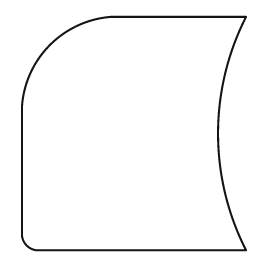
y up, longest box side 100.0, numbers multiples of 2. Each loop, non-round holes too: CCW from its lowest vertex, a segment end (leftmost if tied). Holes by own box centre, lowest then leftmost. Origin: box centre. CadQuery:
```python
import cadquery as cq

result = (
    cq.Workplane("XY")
    .moveTo(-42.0, -50.0)
    .lineTo(48.0, -50.0)
    .threePointArc((36.0, 0.0), (48.0, 50.0))
    .lineTo(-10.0, 50.0)
    .threePointArc((-36.0, 38.0), (-48.0, 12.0))
    .lineTo(-48.0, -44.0)
    .threePointArc((-46.0, -48.0), (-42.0, -50.0))
    .close()
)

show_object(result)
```